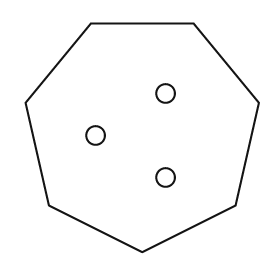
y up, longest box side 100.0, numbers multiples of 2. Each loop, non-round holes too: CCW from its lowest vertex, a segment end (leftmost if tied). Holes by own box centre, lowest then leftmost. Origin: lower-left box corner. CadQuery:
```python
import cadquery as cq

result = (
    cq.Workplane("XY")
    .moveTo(50.0, 0.0)
    .lineTo(90.0, 20.0)
    .lineTo(100.0, 64.0)
    .lineTo(72.0, 98.0)
    .lineTo(28.0, 98.0)
    .lineTo(0.0, 64.0)
    .lineTo(10.0, 20.0)
    .close()
    .moveTo(60.0, 32.0)
    .circle(4.0)
    .moveTo(30.0, 50.0)
    .circle(4.0)
    .moveTo(60.0, 68.0)
    .circle(4.0)
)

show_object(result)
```